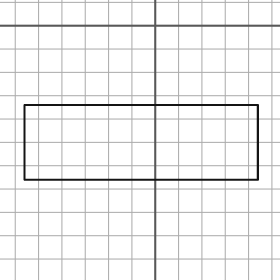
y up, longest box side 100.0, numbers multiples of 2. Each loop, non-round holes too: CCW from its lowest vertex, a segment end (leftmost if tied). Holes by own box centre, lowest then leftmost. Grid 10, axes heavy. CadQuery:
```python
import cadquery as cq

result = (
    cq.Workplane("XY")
    .moveTo(-56.0, -66.0)
    .lineTo(44.0, -66.0)
    .lineTo(44.0, -34.0)
    .lineTo(-56.0, -34.0)
    .close()
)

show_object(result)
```